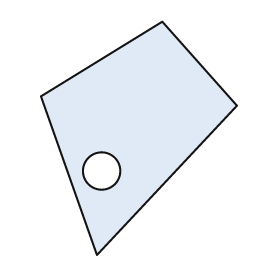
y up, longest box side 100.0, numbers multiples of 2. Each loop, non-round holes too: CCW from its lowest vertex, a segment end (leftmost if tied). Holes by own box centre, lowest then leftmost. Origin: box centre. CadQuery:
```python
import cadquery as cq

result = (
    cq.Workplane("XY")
    .moveTo(-18.0, -50.0)
    .lineTo(42.0, 14.0)
    .lineTo(10.0, 50.0)
    .lineTo(-42.0, 18.0)
    .close()
    .moveTo(-16.0, -14.0)
    .circle(8.0)
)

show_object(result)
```